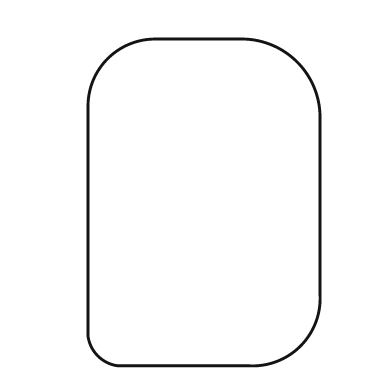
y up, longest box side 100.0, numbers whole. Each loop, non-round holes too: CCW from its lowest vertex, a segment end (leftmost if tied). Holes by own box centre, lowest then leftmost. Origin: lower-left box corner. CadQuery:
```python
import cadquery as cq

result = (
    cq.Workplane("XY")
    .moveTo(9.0, 0.0)
    .lineTo(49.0, 0.0)
    .threePointArc((65.0, 6.0), (71.0, 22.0))
    .lineTo(71.0, 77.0)
    .threePointArc((64.0, 93.0), (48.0, 100.0))
    .lineTo(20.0, 100.0)
    .threePointArc((6.0, 94.0), (0.0, 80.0))
    .lineTo(0.0, 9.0)
    .threePointArc((3.0, 3.0), (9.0, 0.0))
    .close()
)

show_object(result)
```